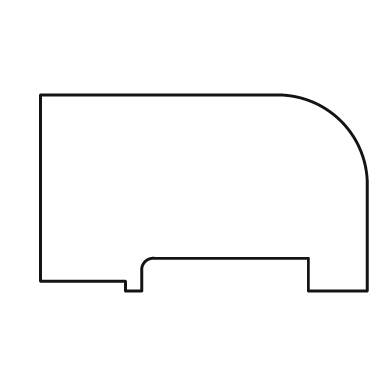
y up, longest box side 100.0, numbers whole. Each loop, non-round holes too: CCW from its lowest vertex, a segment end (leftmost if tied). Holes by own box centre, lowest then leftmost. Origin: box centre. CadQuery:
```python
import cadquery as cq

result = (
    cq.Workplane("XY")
    .moveTo(-24.0, -30.0)
    .lineTo(-19.0, -30.0)
    .lineTo(-19.0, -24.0)
    .threePointArc((-18.0, -21.0), (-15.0, -20.0))
    .lineTo(32.0, -20.0)
    .lineTo(32.0, -30.0)
    .lineTo(50.0, -30.0)
    .lineTo(50.0, 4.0)
    .threePointArc((42.0, 22.0), (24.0, 30.0))
    .lineTo(-50.0, 30.0)
    .lineTo(-50.0, -27.0)
    .lineTo(-24.0, -27.0)
    .close()
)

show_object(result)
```